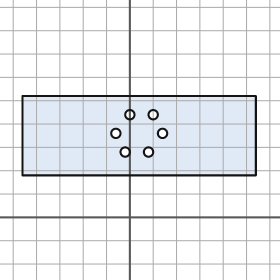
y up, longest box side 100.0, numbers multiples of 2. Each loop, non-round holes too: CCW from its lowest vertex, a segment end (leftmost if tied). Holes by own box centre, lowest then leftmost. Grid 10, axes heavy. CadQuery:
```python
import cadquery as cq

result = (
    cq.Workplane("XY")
    .moveTo(-46.0, 18.0)
    .lineTo(54.0, 18.0)
    .lineTo(54.0, 52.0)
    .lineTo(-46.0, 52.0)
    .close()
    .moveTo(-2.0, 28.0)
    .circle(2.0)
    .moveTo(8.0, 28.0)
    .circle(2.0)
    .moveTo(-6.0, 36.0)
    .circle(2.0)
    .moveTo(14.0, 36.0)
    .circle(2.0)
    .moveTo(0.0, 44.0)
    .circle(2.0)
    .moveTo(10.0, 44.0)
    .circle(2.0)
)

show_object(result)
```